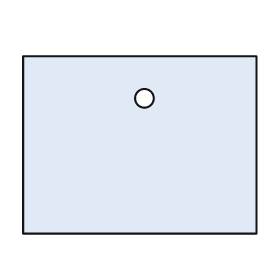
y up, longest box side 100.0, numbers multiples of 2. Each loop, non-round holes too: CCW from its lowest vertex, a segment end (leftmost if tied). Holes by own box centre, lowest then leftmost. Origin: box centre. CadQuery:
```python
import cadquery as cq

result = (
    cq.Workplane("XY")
    .moveTo(-50.0, -38.0)
    .lineTo(50.0, -38.0)
    .lineTo(50.0, 38.0)
    .lineTo(-50.0, 38.0)
    .close()
    .moveTo(2.0, 20.0)
    .circle(4.0)
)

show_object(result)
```